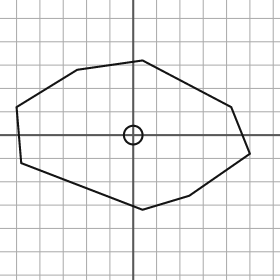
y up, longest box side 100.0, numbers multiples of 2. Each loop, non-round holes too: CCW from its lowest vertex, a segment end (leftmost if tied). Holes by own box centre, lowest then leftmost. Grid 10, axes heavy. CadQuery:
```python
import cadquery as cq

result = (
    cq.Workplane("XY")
    .moveTo(4.0, -32.0)
    .lineTo(24.0, -26.0)
    .lineTo(50.0, -8.0)
    .lineTo(42.0, 12.0)
    .lineTo(4.0, 32.0)
    .lineTo(-24.0, 28.0)
    .lineTo(-50.0, 12.0)
    .lineTo(-48.0, -12.0)
    .close()
    .moveTo(0.0, 0.0)
    .circle(4.0)
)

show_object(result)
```